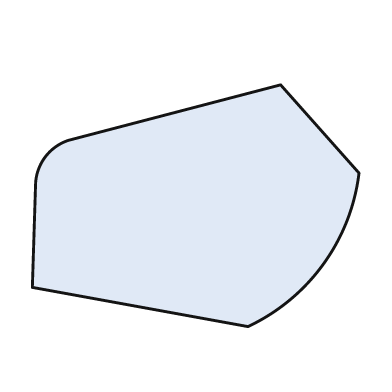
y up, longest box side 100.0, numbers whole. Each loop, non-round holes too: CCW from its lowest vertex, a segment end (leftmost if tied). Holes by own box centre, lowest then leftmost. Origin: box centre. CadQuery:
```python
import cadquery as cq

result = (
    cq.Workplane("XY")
    .moveTo(16.0, -37.0)
    .threePointArc((39.0, -18.0), (50.0, 10.0))
    .lineTo(26.0, 37.0)
    .lineTo(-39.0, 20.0)
    .threePointArc((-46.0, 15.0), (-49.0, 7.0))
    .lineTo(-50.0, -25.0)
    .close()
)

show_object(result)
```